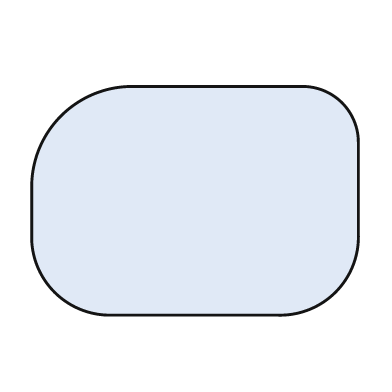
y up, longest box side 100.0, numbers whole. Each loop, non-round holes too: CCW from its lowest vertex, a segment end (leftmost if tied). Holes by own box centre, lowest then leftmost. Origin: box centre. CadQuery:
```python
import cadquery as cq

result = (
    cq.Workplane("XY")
    .moveTo(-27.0, -35.0)
    .lineTo(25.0, -35.0)
    .threePointArc((43.0, -28.0), (50.0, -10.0))
    .lineTo(50.0, 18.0)
    .threePointArc((45.0, 30.0), (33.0, 35.0))
    .lineTo(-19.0, 35.0)
    .threePointArc((-41.0, 26.0), (-50.0, 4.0))
    .lineTo(-50.0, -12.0)
    .threePointArc((-43.0, -28.0), (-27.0, -35.0))
    .close()
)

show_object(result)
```